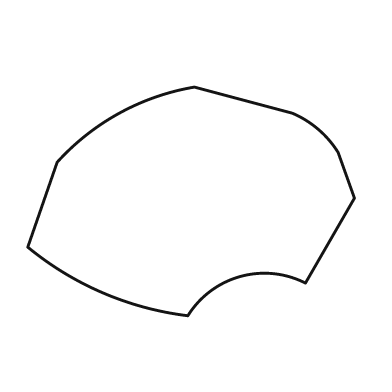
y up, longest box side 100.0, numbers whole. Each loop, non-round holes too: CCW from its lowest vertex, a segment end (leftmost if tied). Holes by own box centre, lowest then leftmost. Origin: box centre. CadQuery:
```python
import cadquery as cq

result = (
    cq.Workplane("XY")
    .moveTo(-1.0, -35.0)
    .threePointArc((15.0, -23.0), (35.0, -25.0))
    .lineTo(50.0, 1.0)
    .lineTo(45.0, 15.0)
    .threePointArc((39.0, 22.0), (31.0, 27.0))
    .lineTo(1.0, 35.0)
    .threePointArc((-22.0, 27.0), (-41.0, 12.0))
    .lineTo(-50.0, -14.0)
    .threePointArc((-27.0, -28.0), (-1.0, -35.0))
    .close()
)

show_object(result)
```